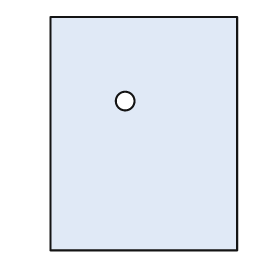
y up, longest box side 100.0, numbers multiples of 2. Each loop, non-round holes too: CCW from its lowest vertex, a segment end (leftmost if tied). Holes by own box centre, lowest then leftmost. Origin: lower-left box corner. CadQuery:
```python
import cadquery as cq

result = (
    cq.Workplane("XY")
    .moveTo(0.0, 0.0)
    .lineTo(80.0, 0.0)
    .lineTo(80.0, 100.0)
    .lineTo(0.0, 100.0)
    .close()
    .moveTo(32.0, 64.0)
    .circle(4.0)
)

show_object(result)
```